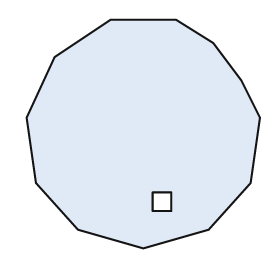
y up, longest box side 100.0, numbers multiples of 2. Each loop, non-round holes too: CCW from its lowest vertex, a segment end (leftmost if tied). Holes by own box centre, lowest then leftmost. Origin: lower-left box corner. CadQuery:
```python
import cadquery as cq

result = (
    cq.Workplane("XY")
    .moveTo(50.0, 0.0)
    .lineTo(78.0, 8.0)
    .lineTo(96.0, 28.0)
    .lineTo(100.0, 56.0)
    .lineTo(92.0, 72.0)
    .lineTo(80.0, 88.0)
    .lineTo(64.0, 98.0)
    .lineTo(36.0, 98.0)
    .lineTo(12.0, 82.0)
    .lineTo(0.0, 56.0)
    .lineTo(4.0, 28.0)
    .lineTo(22.0, 8.0)
    .close()
    .moveTo(54.0, 16.0)
    .lineTo(62.0, 16.0)
    .lineTo(62.0, 24.0)
    .lineTo(54.0, 24.0)
    .close()
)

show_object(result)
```